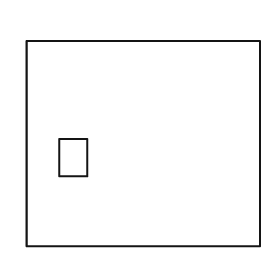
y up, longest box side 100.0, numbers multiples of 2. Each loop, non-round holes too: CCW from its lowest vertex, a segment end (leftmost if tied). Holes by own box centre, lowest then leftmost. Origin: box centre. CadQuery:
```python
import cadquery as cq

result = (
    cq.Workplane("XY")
    .moveTo(-50.0, -44.0)
    .lineTo(50.0, -44.0)
    .lineTo(50.0, 44.0)
    .lineTo(-50.0, 44.0)
    .close()
    .moveTo(-36.0, -14.0)
    .lineTo(-24.0, -14.0)
    .lineTo(-24.0, 2.0)
    .lineTo(-36.0, 2.0)
    .close()
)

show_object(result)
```